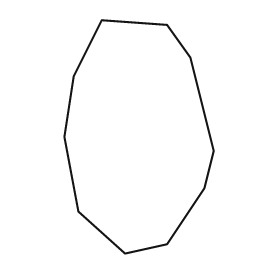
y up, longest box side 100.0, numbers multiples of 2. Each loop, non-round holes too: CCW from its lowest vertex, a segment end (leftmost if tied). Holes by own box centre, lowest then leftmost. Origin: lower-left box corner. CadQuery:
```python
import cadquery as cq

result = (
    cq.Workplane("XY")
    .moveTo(26.0, 0.0)
    .lineTo(44.0, 4.0)
    .lineTo(60.0, 28.0)
    .lineTo(64.0, 44.0)
    .lineTo(54.0, 84.0)
    .lineTo(44.0, 98.0)
    .lineTo(16.0, 100.0)
    .lineTo(4.0, 76.0)
    .lineTo(0.0, 50.0)
    .lineTo(6.0, 18.0)
    .close()
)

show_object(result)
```